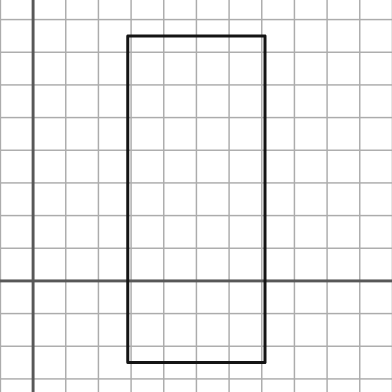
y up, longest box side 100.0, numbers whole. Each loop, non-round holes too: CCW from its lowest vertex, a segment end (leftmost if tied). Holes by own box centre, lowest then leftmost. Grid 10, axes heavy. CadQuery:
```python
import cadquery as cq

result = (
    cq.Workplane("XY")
    .moveTo(29.0, -25.0)
    .lineTo(71.0, -25.0)
    .lineTo(71.0, 75.0)
    .lineTo(29.0, 75.0)
    .close()
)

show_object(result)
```